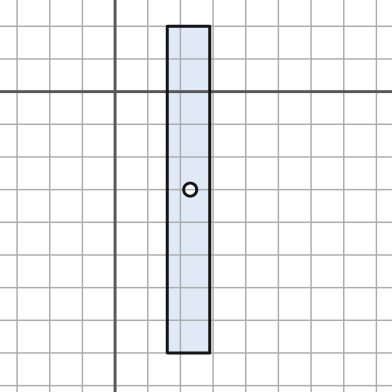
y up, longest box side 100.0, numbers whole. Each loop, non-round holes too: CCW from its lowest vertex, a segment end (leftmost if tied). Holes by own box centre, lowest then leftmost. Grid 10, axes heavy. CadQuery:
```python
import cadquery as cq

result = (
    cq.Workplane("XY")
    .moveTo(16.0, -80.0)
    .lineTo(29.0, -80.0)
    .lineTo(29.0, 20.0)
    .lineTo(16.0, 20.0)
    .close()
    .moveTo(23.0, -30.0)
    .circle(2.0)
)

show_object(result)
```